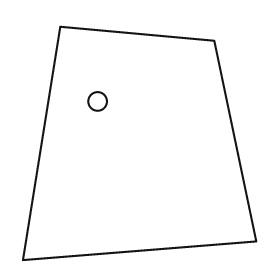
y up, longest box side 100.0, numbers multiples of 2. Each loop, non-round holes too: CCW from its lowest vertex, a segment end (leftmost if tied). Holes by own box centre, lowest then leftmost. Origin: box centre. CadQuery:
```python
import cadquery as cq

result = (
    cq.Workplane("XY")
    .moveTo(-50.0, -50.0)
    .lineTo(50.0, -42.0)
    .lineTo(32.0, 44.0)
    .lineTo(-34.0, 50.0)
    .close()
    .moveTo(-18.0, 18.0)
    .circle(4.0)
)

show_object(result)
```